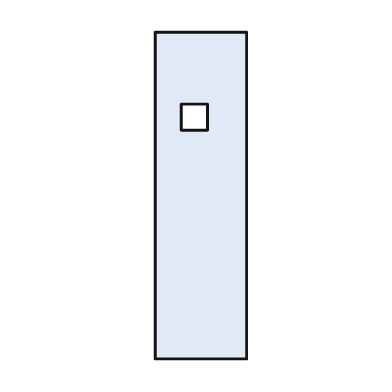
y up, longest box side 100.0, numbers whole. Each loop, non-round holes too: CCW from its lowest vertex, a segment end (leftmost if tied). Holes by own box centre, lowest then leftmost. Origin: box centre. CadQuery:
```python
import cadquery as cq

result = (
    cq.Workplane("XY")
    .moveTo(-14.0, -50.0)
    .lineTo(14.0, -50.0)
    .lineTo(14.0, 50.0)
    .lineTo(-14.0, 50.0)
    .close()
    .moveTo(-6.0, 20.0)
    .lineTo(2.0, 20.0)
    .lineTo(2.0, 28.0)
    .lineTo(-6.0, 28.0)
    .close()
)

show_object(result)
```